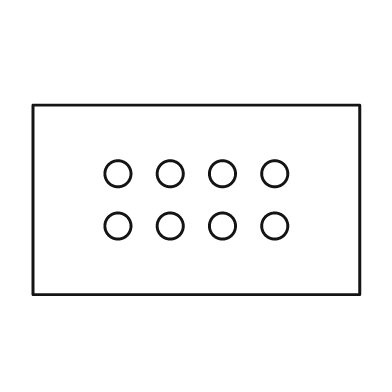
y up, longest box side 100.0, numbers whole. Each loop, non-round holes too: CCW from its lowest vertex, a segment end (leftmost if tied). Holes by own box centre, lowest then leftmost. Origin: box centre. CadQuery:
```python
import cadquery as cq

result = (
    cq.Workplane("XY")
    .moveTo(-50.0, -29.0)
    .lineTo(50.0, -29.0)
    .lineTo(50.0, 29.0)
    .lineTo(-50.0, 29.0)
    .close()
    .moveTo(-24.0, -8.0)
    .circle(4.0)
    .moveTo(-8.0, -8.0)
    .circle(4.0)
    .moveTo(8.0, -8.0)
    .circle(4.0)
    .moveTo(24.0, -8.0)
    .circle(4.0)
    .moveTo(-24.0, 8.0)
    .circle(4.0)
    .moveTo(-8.0, 8.0)
    .circle(4.0)
    .moveTo(8.0, 8.0)
    .circle(4.0)
    .moveTo(24.0, 8.0)
    .circle(4.0)
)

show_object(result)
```